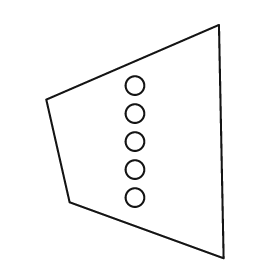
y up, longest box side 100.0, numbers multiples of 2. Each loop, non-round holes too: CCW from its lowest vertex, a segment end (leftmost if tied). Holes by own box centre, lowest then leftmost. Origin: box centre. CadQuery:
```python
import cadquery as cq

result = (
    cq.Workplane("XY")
    .moveTo(38.0, -50.0)
    .lineTo(36.0, 50.0)
    .lineTo(-38.0, 18.0)
    .lineTo(-28.0, -26.0)
    .close()
    .moveTo(0.0, -24.0)
    .circle(4.0)
    .moveTo(0.0, -12.0)
    .circle(4.0)
    .moveTo(0.0, 0.0)
    .circle(4.0)
    .moveTo(0.0, 12.0)
    .circle(4.0)
    .moveTo(0.0, 24.0)
    .circle(4.0)
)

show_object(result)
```